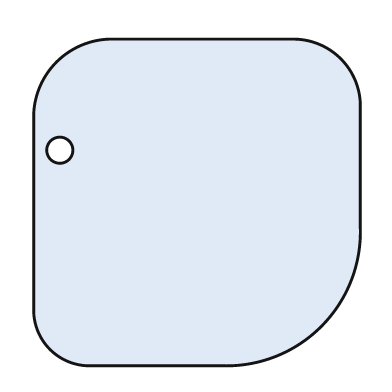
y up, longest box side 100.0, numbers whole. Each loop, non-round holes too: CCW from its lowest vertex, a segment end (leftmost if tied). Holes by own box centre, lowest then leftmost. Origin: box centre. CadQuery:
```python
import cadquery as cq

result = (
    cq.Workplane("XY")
    .moveTo(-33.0, -50.0)
    .lineTo(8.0, -50.0)
    .threePointArc((38.0, -38.0), (50.0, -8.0))
    .lineTo(50.0, 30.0)
    .threePointArc((44.0, 44.0), (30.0, 50.0))
    .lineTo(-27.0, 50.0)
    .threePointArc((-43.0, 43.0), (-50.0, 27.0))
    .lineTo(-50.0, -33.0)
    .threePointArc((-45.0, -45.0), (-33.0, -50.0))
    .close()
    .moveTo(-42.0, 16.0)
    .circle(4.0)
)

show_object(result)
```